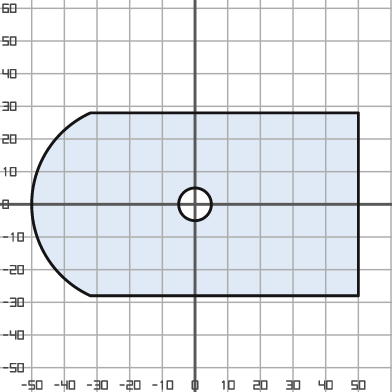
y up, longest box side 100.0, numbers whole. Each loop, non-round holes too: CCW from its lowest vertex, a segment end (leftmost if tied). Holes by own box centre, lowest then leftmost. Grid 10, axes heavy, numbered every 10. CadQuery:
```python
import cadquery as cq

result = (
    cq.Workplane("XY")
    .moveTo(-32.0, -28.0)
    .lineTo(50.0, -28.0)
    .lineTo(50.0, 28.0)
    .lineTo(-32.0, 28.0)
    .threePointArc((-50.0, 0.0), (-32.0, -28.0))
    .close()
    .moveTo(0.0, 0.0)
    .circle(5.0)
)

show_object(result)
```